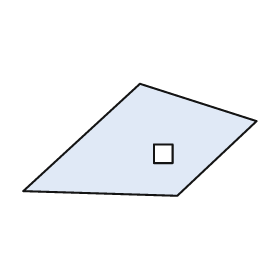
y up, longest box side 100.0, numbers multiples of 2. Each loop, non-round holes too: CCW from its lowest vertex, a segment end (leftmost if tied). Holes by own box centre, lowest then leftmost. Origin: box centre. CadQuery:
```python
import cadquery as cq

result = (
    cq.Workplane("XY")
    .moveTo(16.0, -24.0)
    .lineTo(50.0, 8.0)
    .lineTo(0.0, 24.0)
    .lineTo(-50.0, -22.0)
    .close()
    .moveTo(6.0, -10.0)
    .lineTo(14.0, -10.0)
    .lineTo(14.0, -2.0)
    .lineTo(6.0, -2.0)
    .close()
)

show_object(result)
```